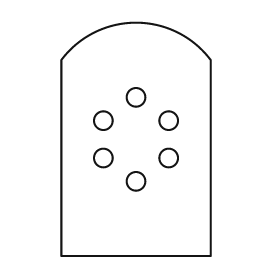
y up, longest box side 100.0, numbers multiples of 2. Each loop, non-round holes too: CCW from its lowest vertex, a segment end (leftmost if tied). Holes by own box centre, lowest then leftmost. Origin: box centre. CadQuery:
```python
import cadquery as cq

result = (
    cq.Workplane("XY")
    .moveTo(-32.0, -50.0)
    .lineTo(32.0, -50.0)
    .lineTo(32.0, 34.0)
    .threePointArc((0.0, 50.0), (-32.0, 34.0))
    .close()
    .moveTo(0.0, -18.0)
    .circle(4.0)
    .moveTo(-14.0, -8.0)
    .circle(4.0)
    .moveTo(14.0, -8.0)
    .circle(4.0)
    .moveTo(-14.0, 8.0)
    .circle(4.0)
    .moveTo(14.0, 8.0)
    .circle(4.0)
    .moveTo(0.0, 18.0)
    .circle(4.0)
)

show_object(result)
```